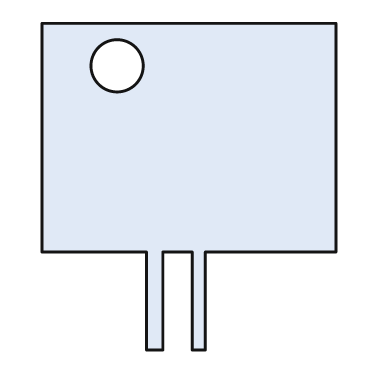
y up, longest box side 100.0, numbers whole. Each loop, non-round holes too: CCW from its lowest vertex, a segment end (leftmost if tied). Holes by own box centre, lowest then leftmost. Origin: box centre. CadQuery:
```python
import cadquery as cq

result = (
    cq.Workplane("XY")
    .moveTo(-13.0, -50.0)
    .lineTo(-8.0, -50.0)
    .lineTo(-8.0, -20.0)
    .lineTo(1.0, -20.0)
    .lineTo(1.0, -50.0)
    .lineTo(5.0, -50.0)
    .lineTo(5.0, -20.0)
    .lineTo(45.0, -20.0)
    .lineTo(45.0, 50.0)
    .lineTo(-45.0, 50.0)
    .lineTo(-45.0, -20.0)
    .lineTo(-13.0, -20.0)
    .close()
    .moveTo(-22.0, 37.0)
    .circle(8.0)
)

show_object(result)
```